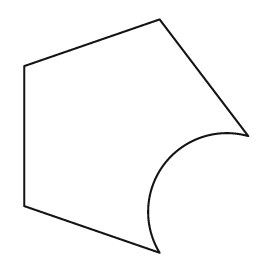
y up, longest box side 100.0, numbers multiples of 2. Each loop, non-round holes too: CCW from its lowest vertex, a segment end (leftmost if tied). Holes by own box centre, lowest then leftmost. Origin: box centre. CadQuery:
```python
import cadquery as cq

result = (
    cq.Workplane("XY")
    .moveTo(10.0, -50.0)
    .threePointArc((12.0, -12.0), (48.0, 0.0))
    .lineTo(10.0, 50.0)
    .lineTo(-48.0, 30.0)
    .lineTo(-48.0, -30.0)
    .close()
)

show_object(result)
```